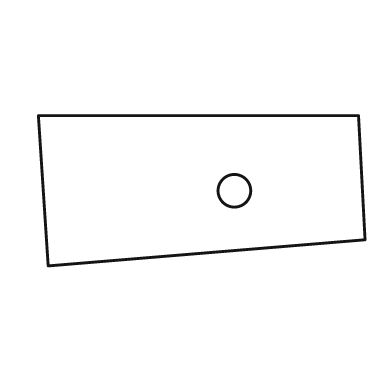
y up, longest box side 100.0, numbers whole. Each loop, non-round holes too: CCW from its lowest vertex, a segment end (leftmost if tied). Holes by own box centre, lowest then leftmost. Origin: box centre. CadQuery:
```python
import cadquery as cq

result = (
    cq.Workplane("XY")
    .moveTo(-47.0, -23.0)
    .lineTo(50.0, -15.0)
    .lineTo(48.0, 23.0)
    .lineTo(-50.0, 23.0)
    .close()
    .moveTo(10.0, 0.0)
    .circle(5.0)
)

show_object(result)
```